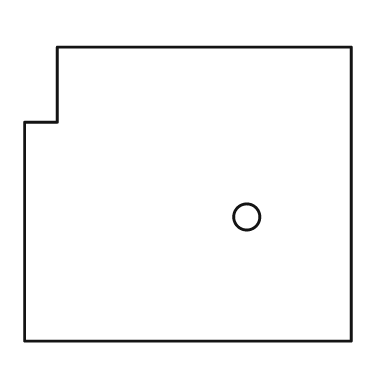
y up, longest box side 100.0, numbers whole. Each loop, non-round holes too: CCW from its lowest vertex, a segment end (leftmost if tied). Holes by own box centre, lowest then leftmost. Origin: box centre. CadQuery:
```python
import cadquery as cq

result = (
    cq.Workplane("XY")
    .moveTo(-50.0, -45.0)
    .lineTo(50.0, -45.0)
    .lineTo(50.0, 45.0)
    .lineTo(-40.0, 45.0)
    .lineTo(-40.0, 22.0)
    .lineTo(-50.0, 22.0)
    .close()
    .moveTo(18.0, -7.0)
    .circle(4.0)
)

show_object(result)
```